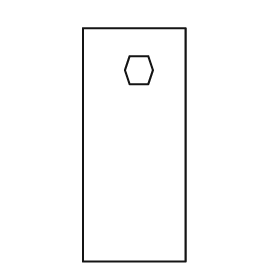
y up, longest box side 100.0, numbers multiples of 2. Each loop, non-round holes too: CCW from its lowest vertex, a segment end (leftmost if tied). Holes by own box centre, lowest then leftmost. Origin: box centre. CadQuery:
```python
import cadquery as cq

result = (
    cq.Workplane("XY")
    .moveTo(-22.0, -50.0)
    .lineTo(22.0, -50.0)
    .lineTo(22.0, 50.0)
    .lineTo(-22.0, 50.0)
    .close()
    .moveTo(-2.0, 26.0)
    .lineTo(6.0, 26.0)
    .lineTo(8.0, 32.0)
    .lineTo(6.0, 38.0)
    .lineTo(-2.0, 38.0)
    .lineTo(-4.0, 32.0)
    .close()
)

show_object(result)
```